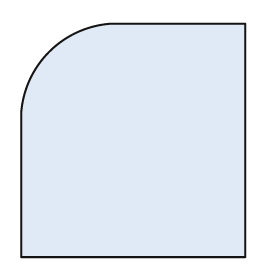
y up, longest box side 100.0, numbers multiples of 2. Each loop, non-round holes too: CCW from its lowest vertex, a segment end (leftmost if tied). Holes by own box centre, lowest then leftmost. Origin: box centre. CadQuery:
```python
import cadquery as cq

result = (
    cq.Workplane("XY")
    .moveTo(-48.0, -50.0)
    .lineTo(48.0, -50.0)
    .lineTo(48.0, 50.0)
    .lineTo(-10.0, 50.0)
    .threePointArc((-36.0, 38.0), (-48.0, 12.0))
    .close()
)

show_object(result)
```